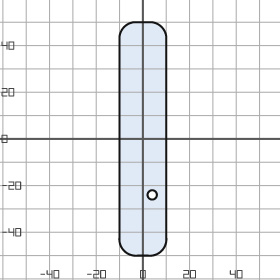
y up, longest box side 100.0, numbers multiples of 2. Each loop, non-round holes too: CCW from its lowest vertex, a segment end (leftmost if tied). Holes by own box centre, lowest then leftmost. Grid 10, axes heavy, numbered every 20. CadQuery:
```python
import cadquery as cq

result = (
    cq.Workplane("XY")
    .moveTo(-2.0, -50.0)
    .lineTo(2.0, -50.0)
    .threePointArc((8.0, -48.0), (10.0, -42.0))
    .lineTo(10.0, 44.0)
    .threePointArc((8.0, 48.0), (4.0, 50.0))
    .lineTo(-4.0, 50.0)
    .threePointArc((-8.0, 48.0), (-10.0, 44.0))
    .lineTo(-10.0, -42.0)
    .threePointArc((-8.0, -48.0), (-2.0, -50.0))
    .close()
    .moveTo(4.0, -24.0)
    .circle(2.0)
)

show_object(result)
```